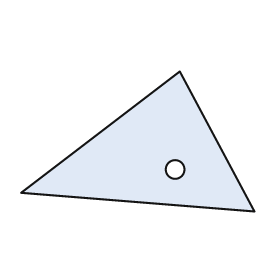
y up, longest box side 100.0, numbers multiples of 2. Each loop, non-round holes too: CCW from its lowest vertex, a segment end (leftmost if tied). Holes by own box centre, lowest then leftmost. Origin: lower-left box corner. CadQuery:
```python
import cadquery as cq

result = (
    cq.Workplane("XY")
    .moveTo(100.0, 0.0)
    .lineTo(68.0, 60.0)
    .lineTo(0.0, 8.0)
    .close()
    .moveTo(66.0, 18.0)
    .circle(4.0)
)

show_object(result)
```